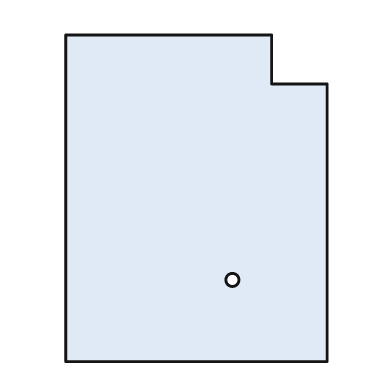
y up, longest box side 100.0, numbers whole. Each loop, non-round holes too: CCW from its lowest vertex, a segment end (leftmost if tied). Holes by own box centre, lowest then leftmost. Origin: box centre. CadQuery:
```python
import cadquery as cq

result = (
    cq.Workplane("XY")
    .moveTo(-40.0, -50.0)
    .lineTo(40.0, -50.0)
    .lineTo(40.0, 35.0)
    .lineTo(23.0, 35.0)
    .lineTo(23.0, 50.0)
    .lineTo(-40.0, 50.0)
    .close()
    .moveTo(11.0, -25.0)
    .circle(2.0)
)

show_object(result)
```